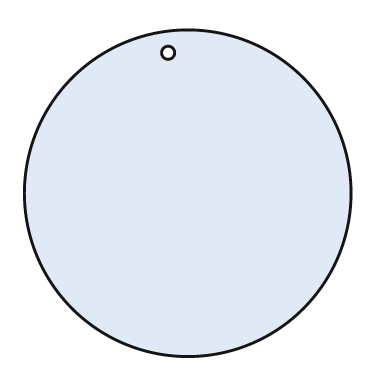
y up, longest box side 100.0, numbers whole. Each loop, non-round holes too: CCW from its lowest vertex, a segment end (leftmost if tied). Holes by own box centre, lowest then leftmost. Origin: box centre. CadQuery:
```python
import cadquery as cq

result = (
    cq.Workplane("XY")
    .moveTo(0.0, 0.0)
    .circle(50.0)
    .moveTo(-6.0, 43.0)
    .circle(2.0)
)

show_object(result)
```